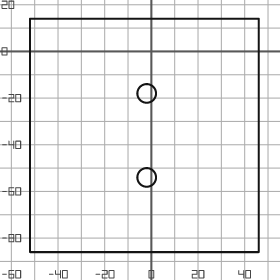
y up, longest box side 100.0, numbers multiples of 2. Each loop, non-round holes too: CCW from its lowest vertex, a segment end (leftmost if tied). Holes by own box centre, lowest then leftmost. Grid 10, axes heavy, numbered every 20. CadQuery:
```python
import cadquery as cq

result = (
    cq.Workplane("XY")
    .moveTo(-52.0, -86.0)
    .lineTo(46.0, -86.0)
    .lineTo(46.0, 14.0)
    .lineTo(-52.0, 14.0)
    .close()
    .moveTo(-2.0, -54.0)
    .circle(4.0)
    .moveTo(-2.0, -18.0)
    .circle(4.0)
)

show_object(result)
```